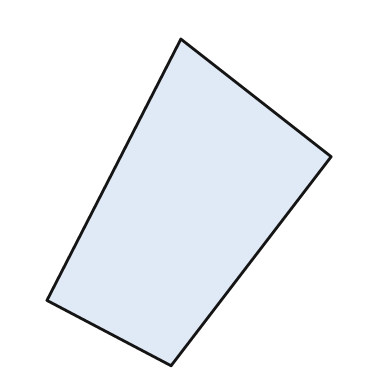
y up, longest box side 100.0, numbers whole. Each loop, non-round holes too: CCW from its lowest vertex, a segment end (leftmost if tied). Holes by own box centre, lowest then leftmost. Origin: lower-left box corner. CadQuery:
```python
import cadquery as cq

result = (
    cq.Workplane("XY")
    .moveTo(38.0, 0.0)
    .lineTo(87.0, 64.0)
    .lineTo(41.0, 100.0)
    .lineTo(0.0, 20.0)
    .close()
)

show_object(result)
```